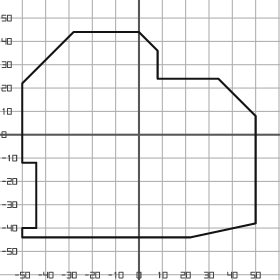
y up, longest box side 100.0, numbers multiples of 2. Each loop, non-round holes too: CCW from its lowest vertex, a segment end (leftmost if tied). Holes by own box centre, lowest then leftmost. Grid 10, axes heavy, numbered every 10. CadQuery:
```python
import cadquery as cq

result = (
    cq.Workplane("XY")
    .moveTo(-50.0, -44.0)
    .lineTo(22.0, -44.0)
    .lineTo(50.0, -38.0)
    .lineTo(50.0, 8.0)
    .lineTo(34.0, 24.0)
    .lineTo(8.0, 24.0)
    .lineTo(8.0, 36.0)
    .lineTo(0.0, 44.0)
    .lineTo(-28.0, 44.0)
    .lineTo(-50.0, 22.0)
    .lineTo(-50.0, -12.0)
    .lineTo(-44.0, -12.0)
    .lineTo(-44.0, -40.0)
    .lineTo(-50.0, -40.0)
    .close()
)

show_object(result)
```